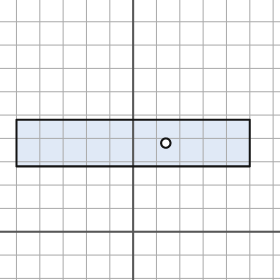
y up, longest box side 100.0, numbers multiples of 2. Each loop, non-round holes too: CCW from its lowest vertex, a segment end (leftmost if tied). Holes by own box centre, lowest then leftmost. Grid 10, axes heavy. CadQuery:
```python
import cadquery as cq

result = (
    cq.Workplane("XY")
    .moveTo(-50.0, 28.0)
    .lineTo(50.0, 28.0)
    .lineTo(50.0, 48.0)
    .lineTo(-50.0, 48.0)
    .close()
    .moveTo(14.0, 38.0)
    .circle(2.0)
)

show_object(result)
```